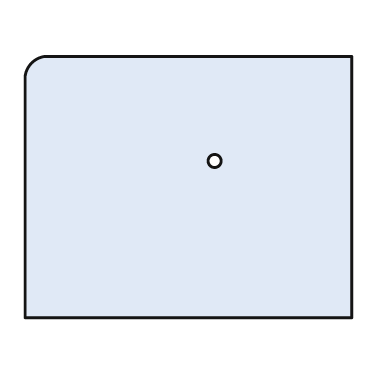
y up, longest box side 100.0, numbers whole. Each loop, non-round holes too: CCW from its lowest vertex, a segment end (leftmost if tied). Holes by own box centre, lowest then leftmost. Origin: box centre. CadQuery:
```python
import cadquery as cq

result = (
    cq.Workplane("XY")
    .moveTo(-50.0, -40.0)
    .lineTo(50.0, -40.0)
    .lineTo(50.0, 40.0)
    .lineTo(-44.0, 40.0)
    .threePointArc((-48.0, 38.0), (-50.0, 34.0))
    .close()
    .moveTo(8.0, 8.0)
    .circle(2.0)
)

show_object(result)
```